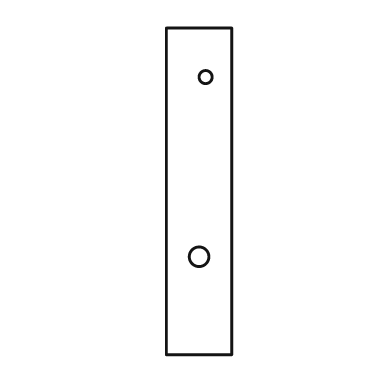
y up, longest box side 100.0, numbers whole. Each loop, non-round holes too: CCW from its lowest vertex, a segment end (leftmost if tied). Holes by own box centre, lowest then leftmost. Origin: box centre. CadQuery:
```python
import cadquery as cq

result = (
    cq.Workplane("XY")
    .moveTo(-10.0, -50.0)
    .lineTo(10.0, -50.0)
    .lineTo(10.0, 50.0)
    .lineTo(-10.0, 50.0)
    .close()
    .moveTo(0.0, -20.0)
    .circle(3.0)
    .moveTo(2.0, 35.0)
    .circle(2.0)
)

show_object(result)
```